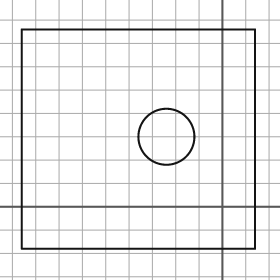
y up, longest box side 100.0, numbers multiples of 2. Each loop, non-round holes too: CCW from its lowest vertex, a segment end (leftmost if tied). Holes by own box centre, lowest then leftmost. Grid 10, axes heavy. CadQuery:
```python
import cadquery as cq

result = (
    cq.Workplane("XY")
    .moveTo(-86.0, -18.0)
    .lineTo(14.0, -18.0)
    .lineTo(14.0, 76.0)
    .lineTo(-86.0, 76.0)
    .close()
    .moveTo(-24.0, 30.0)
    .circle(12.0)
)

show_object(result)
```